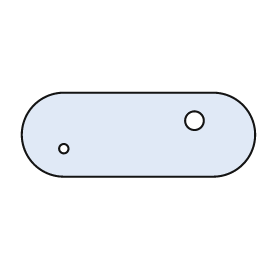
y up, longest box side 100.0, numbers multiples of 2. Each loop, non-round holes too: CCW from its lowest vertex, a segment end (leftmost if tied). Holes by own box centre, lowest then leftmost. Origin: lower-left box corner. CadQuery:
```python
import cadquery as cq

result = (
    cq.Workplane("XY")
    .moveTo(18.0, 0.0)
    .lineTo(82.0, 0.0)
    .threePointArc((100.0, 18.0), (82.0, 36.0))
    .lineTo(18.0, 36.0)
    .threePointArc((0.0, 18.0), (18.0, 0.0))
    .close()
    .moveTo(18.0, 12.0)
    .circle(2.0)
    .moveTo(74.0, 24.0)
    .circle(4.0)
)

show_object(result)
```